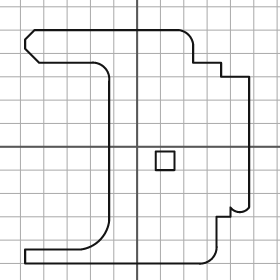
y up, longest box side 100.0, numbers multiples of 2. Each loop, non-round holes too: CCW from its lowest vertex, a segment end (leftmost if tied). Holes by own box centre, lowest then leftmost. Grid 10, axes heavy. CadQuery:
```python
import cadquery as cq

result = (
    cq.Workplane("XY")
    .moveTo(-48.0, -50.0)
    .lineTo(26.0, -50.0)
    .threePointArc((32.0, -48.0), (34.0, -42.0))
    .lineTo(34.0, -30.0)
    .lineTo(40.0, -30.0)
    .lineTo(40.0, -26.0)
    .threePointArc((44.0, -28.0), (48.0, -26.0))
    .lineTo(48.0, 30.0)
    .lineTo(36.0, 30.0)
    .lineTo(36.0, 36.0)
    .lineTo(24.0, 36.0)
    .lineTo(24.0, 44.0)
    .threePointArc((22.0, 48.0), (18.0, 50.0))
    .lineTo(-44.0, 50.0)
    .lineTo(-48.0, 46.0)
    .lineTo(-48.0, 42.0)
    .lineTo(-42.0, 36.0)
    .lineTo(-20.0, 36.0)
    .threePointArc((-14.0, 34.0), (-12.0, 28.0))
    .lineTo(-12.0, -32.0)
    .threePointArc((-16.0, -40.0), (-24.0, -44.0))
    .lineTo(-48.0, -44.0)
    .close()
    .moveTo(8.0, -10.0)
    .lineTo(16.0, -10.0)
    .lineTo(16.0, -2.0)
    .lineTo(8.0, -2.0)
    .close()
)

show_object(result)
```